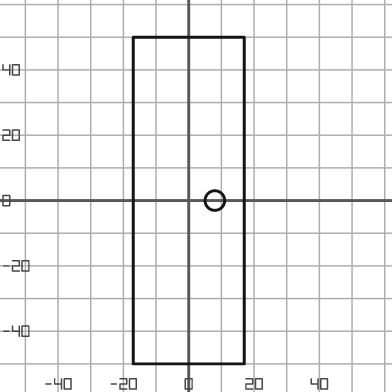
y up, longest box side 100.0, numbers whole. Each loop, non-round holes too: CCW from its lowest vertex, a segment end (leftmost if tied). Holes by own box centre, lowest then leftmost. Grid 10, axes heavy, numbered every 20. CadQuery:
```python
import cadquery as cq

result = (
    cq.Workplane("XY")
    .moveTo(-17.0, -50.0)
    .lineTo(17.0, -50.0)
    .lineTo(17.0, 50.0)
    .lineTo(-17.0, 50.0)
    .close()
    .moveTo(8.0, 0.0)
    .circle(3.0)
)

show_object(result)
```